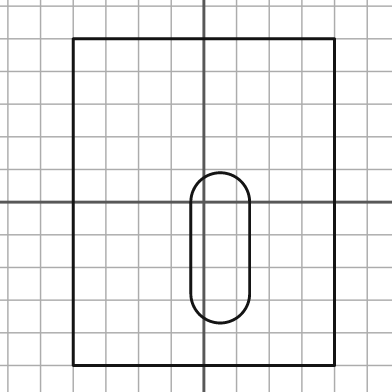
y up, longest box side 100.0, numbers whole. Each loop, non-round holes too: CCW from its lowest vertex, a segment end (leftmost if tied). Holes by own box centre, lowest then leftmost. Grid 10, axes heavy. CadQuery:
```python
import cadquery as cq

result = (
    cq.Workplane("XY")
    .moveTo(-40.0, -50.0)
    .lineTo(40.0, -50.0)
    .lineTo(40.0, 50.0)
    .lineTo(-40.0, 50.0)
    .close()
    .moveTo(-4.0, -28.0)
    .threePointArc((5.0, -37.0), (14.0, -28.0))
    .lineTo(14.0, 0.0)
    .threePointArc((5.0, 9.0), (-4.0, 0.0))
    .close()
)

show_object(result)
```